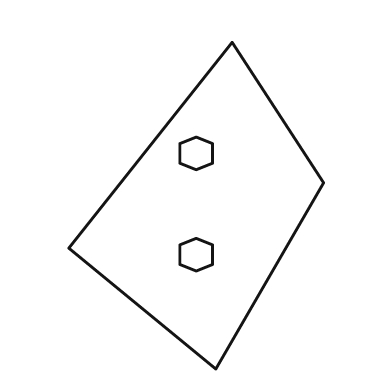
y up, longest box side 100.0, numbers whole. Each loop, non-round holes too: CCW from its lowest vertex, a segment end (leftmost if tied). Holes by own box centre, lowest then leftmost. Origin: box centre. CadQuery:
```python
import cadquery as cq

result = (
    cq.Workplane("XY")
    .moveTo(6.0, -50.0)
    .lineTo(39.0, 7.0)
    .lineTo(11.0, 50.0)
    .lineTo(-39.0, -13.0)
    .close()
    .moveTo(0.0, -20.0)
    .lineTo(5.0, -18.0)
    .lineTo(5.0, -12.0)
    .lineTo(0.0, -10.0)
    .lineTo(-5.0, -12.0)
    .lineTo(-5.0, -18.0)
    .close()
    .moveTo(0.0, 11.0)
    .lineTo(5.0, 13.0)
    .lineTo(5.0, 19.0)
    .lineTo(0.0, 21.0)
    .lineTo(-5.0, 19.0)
    .lineTo(-5.0, 13.0)
    .close()
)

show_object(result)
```